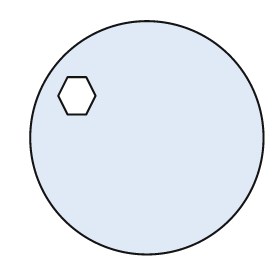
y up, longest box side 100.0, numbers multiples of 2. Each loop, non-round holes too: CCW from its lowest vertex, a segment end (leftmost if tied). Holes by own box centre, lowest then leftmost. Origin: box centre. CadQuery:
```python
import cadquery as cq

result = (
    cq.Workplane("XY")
    .moveTo(0.0, 0.0)
    .circle(50.0)
    .moveTo(-34.0, 10.0)
    .lineTo(-26.0, 10.0)
    .lineTo(-22.0, 18.0)
    .lineTo(-26.0, 26.0)
    .lineTo(-34.0, 26.0)
    .lineTo(-38.0, 18.0)
    .close()
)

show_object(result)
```